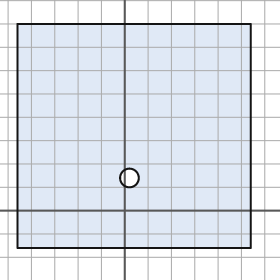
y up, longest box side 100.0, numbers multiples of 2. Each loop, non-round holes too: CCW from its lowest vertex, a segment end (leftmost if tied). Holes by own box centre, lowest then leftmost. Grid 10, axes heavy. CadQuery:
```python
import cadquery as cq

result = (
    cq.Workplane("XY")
    .moveTo(-46.0, -16.0)
    .lineTo(54.0, -16.0)
    .lineTo(54.0, 80.0)
    .lineTo(-46.0, 80.0)
    .close()
    .moveTo(2.0, 14.0)
    .circle(4.0)
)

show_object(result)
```